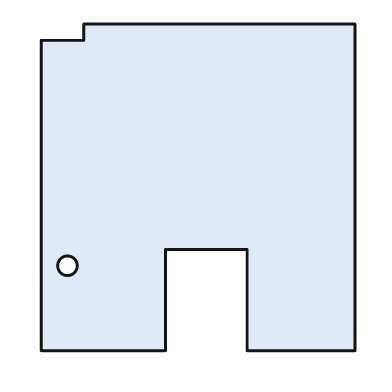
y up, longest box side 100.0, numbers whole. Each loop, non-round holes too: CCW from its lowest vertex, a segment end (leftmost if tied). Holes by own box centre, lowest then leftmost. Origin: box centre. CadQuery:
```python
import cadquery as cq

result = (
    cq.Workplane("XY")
    .moveTo(-48.0, -50.0)
    .lineTo(-10.0, -50.0)
    .lineTo(-10.0, -19.0)
    .lineTo(15.0, -19.0)
    .lineTo(15.0, -50.0)
    .lineTo(48.0, -50.0)
    .lineTo(48.0, 50.0)
    .lineTo(-35.0, 50.0)
    .lineTo(-35.0, 45.0)
    .lineTo(-48.0, 45.0)
    .close()
    .moveTo(-40.0, -24.0)
    .circle(3.0)
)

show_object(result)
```